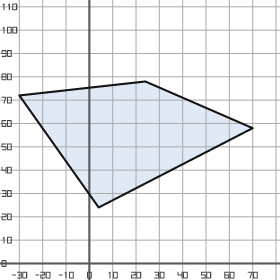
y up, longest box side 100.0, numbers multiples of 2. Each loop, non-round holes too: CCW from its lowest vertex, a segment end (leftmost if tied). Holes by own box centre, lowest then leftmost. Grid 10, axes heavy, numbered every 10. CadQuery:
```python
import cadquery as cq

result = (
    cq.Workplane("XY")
    .moveTo(4.0, 24.0)
    .lineTo(70.0, 58.0)
    .lineTo(24.0, 78.0)
    .lineTo(-30.0, 72.0)
    .close()
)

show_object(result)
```